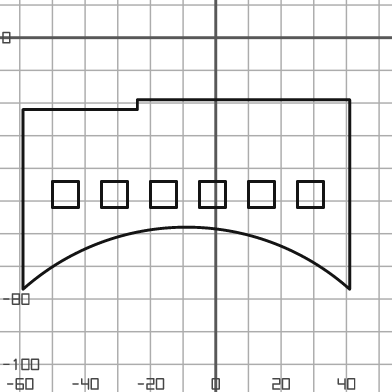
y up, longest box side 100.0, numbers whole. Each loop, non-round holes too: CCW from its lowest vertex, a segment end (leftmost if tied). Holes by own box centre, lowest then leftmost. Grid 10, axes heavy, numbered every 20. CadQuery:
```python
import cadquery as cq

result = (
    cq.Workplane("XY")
    .moveTo(-59.0, -77.0)
    .threePointArc((-9.0, -58.0), (41.0, -77.0))
    .lineTo(41.0, -19.0)
    .lineTo(-24.0, -19.0)
    .lineTo(-24.0, -22.0)
    .lineTo(-59.0, -22.0)
    .close()
    .moveTo(-50.0, -52.0)
    .lineTo(-42.0, -52.0)
    .lineTo(-42.0, -44.0)
    .lineTo(-50.0, -44.0)
    .close()
    .moveTo(-35.0, -52.0)
    .lineTo(-27.0, -52.0)
    .lineTo(-27.0, -44.0)
    .lineTo(-35.0, -44.0)
    .close()
    .moveTo(-20.0, -52.0)
    .lineTo(-12.0, -52.0)
    .lineTo(-12.0, -44.0)
    .lineTo(-20.0, -44.0)
    .close()
    .moveTo(-5.0, -52.0)
    .lineTo(3.0, -52.0)
    .lineTo(3.0, -44.0)
    .lineTo(-5.0, -44.0)
    .close()
    .moveTo(10.0, -52.0)
    .lineTo(18.0, -52.0)
    .lineTo(18.0, -44.0)
    .lineTo(10.0, -44.0)
    .close()
    .moveTo(25.0, -52.0)
    .lineTo(33.0, -52.0)
    .lineTo(33.0, -44.0)
    .lineTo(25.0, -44.0)
    .close()
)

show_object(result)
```